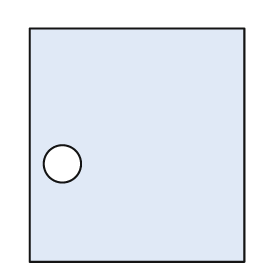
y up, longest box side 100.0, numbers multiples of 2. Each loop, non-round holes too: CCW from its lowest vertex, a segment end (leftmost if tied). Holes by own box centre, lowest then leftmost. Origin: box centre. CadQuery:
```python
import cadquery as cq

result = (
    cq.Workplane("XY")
    .moveTo(-46.0, -50.0)
    .lineTo(46.0, -50.0)
    .lineTo(46.0, 50.0)
    .lineTo(-46.0, 50.0)
    .close()
    .moveTo(-32.0, -8.0)
    .circle(8.0)
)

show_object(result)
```